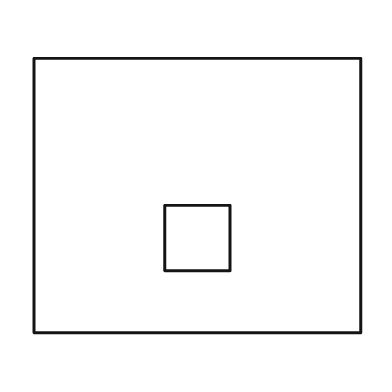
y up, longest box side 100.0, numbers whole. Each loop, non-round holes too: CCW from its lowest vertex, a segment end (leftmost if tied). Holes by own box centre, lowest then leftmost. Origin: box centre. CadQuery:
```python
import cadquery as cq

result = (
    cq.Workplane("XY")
    .moveTo(-50.0, -42.0)
    .lineTo(50.0, -42.0)
    .lineTo(50.0, 42.0)
    .lineTo(-50.0, 42.0)
    .close()
    .moveTo(-10.0, -23.0)
    .lineTo(10.0, -23.0)
    .lineTo(10.0, -3.0)
    .lineTo(-10.0, -3.0)
    .close()
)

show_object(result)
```